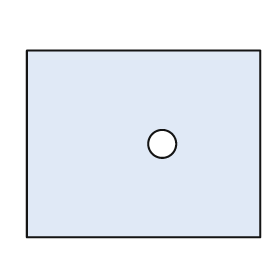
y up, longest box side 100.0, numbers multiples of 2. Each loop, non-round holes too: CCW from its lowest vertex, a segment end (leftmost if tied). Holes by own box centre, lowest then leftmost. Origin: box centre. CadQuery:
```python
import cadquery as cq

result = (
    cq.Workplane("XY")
    .moveTo(-50.0, -40.0)
    .lineTo(50.0, -40.0)
    .lineTo(50.0, 40.0)
    .lineTo(-50.0, 40.0)
    .close()
    .moveTo(8.0, 0.0)
    .circle(6.0)
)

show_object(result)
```